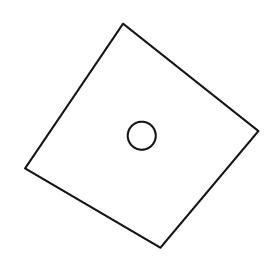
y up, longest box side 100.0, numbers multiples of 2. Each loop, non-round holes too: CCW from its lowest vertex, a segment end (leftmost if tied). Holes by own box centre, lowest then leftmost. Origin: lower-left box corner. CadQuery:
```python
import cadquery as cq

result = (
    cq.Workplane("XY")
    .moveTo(58.0, 0.0)
    .lineTo(100.0, 50.0)
    .lineTo(42.0, 96.0)
    .lineTo(0.0, 34.0)
    .close()
    .moveTo(50.0, 48.0)
    .circle(6.0)
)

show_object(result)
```